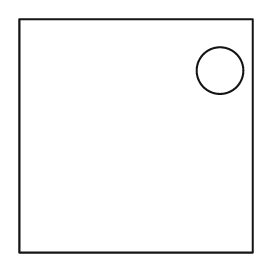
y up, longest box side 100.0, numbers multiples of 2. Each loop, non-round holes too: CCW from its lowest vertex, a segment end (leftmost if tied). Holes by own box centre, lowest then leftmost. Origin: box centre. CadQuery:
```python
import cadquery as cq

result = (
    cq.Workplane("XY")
    .moveTo(-50.0, -50.0)
    .lineTo(50.0, -50.0)
    .lineTo(50.0, 50.0)
    .lineTo(-50.0, 50.0)
    .close()
    .moveTo(36.0, 28.0)
    .circle(10.0)
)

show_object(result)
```